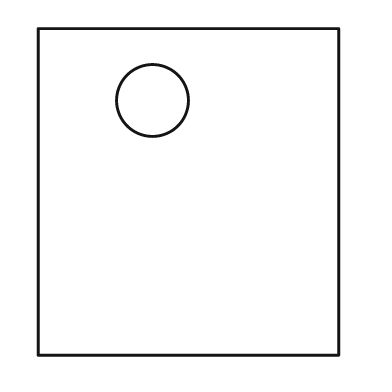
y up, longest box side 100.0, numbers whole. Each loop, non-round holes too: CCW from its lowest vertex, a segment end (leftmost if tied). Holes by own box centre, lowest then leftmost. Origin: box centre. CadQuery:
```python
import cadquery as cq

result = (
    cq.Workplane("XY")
    .moveTo(-46.0, -50.0)
    .lineTo(46.0, -50.0)
    .lineTo(46.0, 50.0)
    .lineTo(-46.0, 50.0)
    .close()
    .moveTo(-11.0, 28.0)
    .circle(11.0)
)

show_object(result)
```